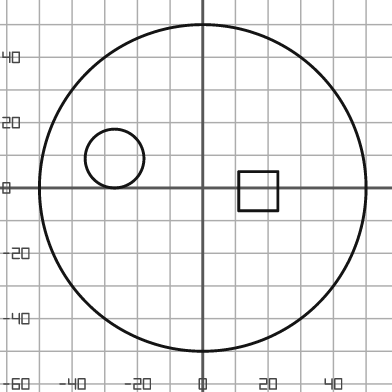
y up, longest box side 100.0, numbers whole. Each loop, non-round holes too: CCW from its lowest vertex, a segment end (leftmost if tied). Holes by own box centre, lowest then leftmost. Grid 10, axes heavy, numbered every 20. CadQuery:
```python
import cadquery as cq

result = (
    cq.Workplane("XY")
    .moveTo(0.0, 0.0)
    .circle(50.0)
    .moveTo(11.0, -7.0)
    .lineTo(23.0, -7.0)
    .lineTo(23.0, 5.0)
    .lineTo(11.0, 5.0)
    .close()
    .moveTo(-27.0, 9.0)
    .circle(9.0)
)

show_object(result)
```